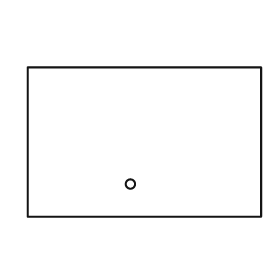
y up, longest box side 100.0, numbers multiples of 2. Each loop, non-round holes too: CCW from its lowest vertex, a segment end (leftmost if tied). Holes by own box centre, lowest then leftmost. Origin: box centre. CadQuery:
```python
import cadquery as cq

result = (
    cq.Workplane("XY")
    .moveTo(-50.0, -32.0)
    .lineTo(50.0, -32.0)
    .lineTo(50.0, 32.0)
    .lineTo(-50.0, 32.0)
    .close()
    .moveTo(-6.0, -18.0)
    .circle(2.0)
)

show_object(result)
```